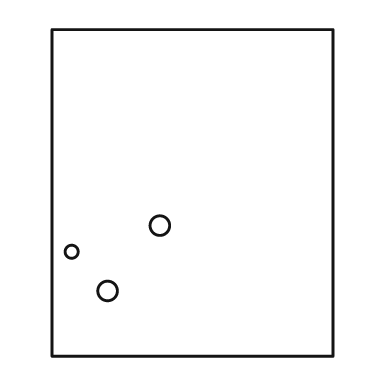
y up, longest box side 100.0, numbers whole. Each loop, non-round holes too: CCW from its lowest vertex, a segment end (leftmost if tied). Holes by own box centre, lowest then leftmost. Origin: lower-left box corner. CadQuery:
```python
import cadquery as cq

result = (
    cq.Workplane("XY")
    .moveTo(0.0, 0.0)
    .lineTo(86.0, 0.0)
    .lineTo(86.0, 100.0)
    .lineTo(0.0, 100.0)
    .close()
    .moveTo(17.0, 20.0)
    .circle(3.0)
    .moveTo(6.0, 32.0)
    .circle(2.0)
    .moveTo(33.0, 40.0)
    .circle(3.0)
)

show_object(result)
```